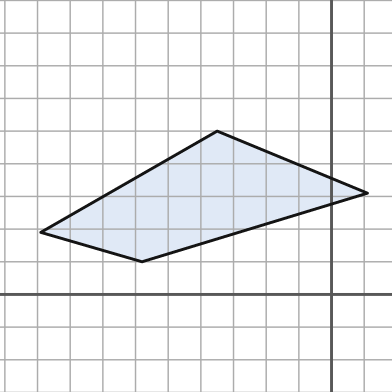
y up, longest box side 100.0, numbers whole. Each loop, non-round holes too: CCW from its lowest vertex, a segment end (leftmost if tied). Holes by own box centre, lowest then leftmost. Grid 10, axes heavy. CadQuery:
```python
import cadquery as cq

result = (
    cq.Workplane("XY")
    .moveTo(-58.0, 10.0)
    .lineTo(11.0, 31.0)
    .lineTo(-35.0, 50.0)
    .lineTo(-89.0, 19.0)
    .close()
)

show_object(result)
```